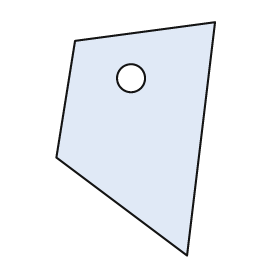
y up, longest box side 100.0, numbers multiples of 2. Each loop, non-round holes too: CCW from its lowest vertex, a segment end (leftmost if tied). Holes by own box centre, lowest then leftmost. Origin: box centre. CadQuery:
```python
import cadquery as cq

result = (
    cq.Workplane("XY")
    .moveTo(22.0, -50.0)
    .lineTo(34.0, 50.0)
    .lineTo(-26.0, 42.0)
    .lineTo(-34.0, -8.0)
    .close()
    .moveTo(-2.0, 26.0)
    .circle(6.0)
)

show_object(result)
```